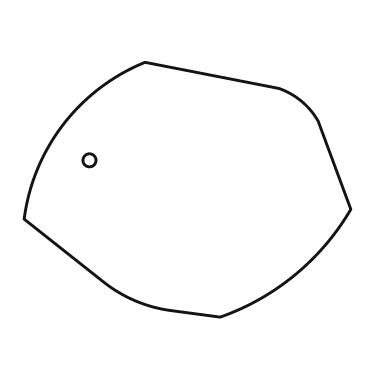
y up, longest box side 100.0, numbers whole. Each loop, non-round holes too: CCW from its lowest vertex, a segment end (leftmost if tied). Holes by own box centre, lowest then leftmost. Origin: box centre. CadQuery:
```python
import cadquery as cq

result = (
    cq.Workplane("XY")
    .moveTo(10.0, -39.0)
    .threePointArc((33.0, -26.0), (50.0, -6.0))
    .lineTo(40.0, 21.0)
    .threePointArc((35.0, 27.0), (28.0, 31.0))
    .lineTo(-13.0, 39.0)
    .threePointArc((-38.0, 20.0), (-50.0, -9.0))
    .lineTo(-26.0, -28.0)
    .threePointArc((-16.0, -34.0), (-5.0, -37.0))
    .close()
    .moveTo(-30.0, 9.0)
    .circle(2.0)
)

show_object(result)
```